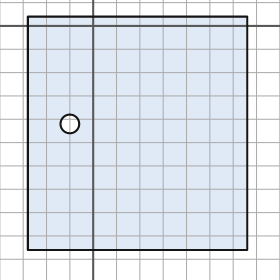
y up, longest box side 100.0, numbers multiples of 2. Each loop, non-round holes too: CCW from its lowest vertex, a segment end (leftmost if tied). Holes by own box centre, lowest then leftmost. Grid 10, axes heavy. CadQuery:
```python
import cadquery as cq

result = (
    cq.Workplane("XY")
    .moveTo(-28.0, -96.0)
    .lineTo(66.0, -96.0)
    .lineTo(66.0, 4.0)
    .lineTo(-28.0, 4.0)
    .close()
    .moveTo(-10.0, -42.0)
    .circle(4.0)
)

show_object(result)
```